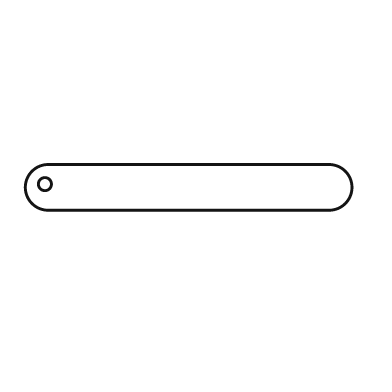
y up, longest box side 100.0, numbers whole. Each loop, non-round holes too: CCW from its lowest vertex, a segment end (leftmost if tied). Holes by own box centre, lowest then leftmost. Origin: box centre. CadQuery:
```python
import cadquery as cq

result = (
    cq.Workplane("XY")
    .moveTo(-43.0, -7.0)
    .lineTo(43.0, -7.0)
    .threePointArc((50.0, 0.0), (43.0, 7.0))
    .lineTo(-43.0, 7.0)
    .threePointArc((-50.0, 0.0), (-43.0, -7.0))
    .close()
    .moveTo(-44.0, 1.0)
    .circle(2.0)
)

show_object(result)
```